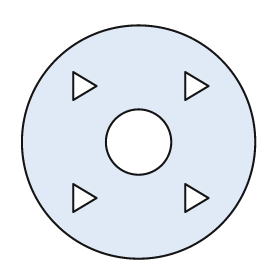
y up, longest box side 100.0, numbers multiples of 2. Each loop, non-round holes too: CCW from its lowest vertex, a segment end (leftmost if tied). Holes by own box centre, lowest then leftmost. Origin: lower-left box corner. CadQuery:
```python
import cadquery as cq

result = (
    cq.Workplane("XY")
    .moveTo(50.0, 50.0)
    .circle(50.0)
    .moveTo(22.0, 20.0)
    .lineTo(32.0, 26.0)
    .lineTo(22.0, 32.0)
    .close()
    .moveTo(70.0, 20.0)
    .lineTo(80.0, 26.0)
    .lineTo(70.0, 32.0)
    .close()
    .moveTo(50.0, 50.0)
    .circle(14.0)
    .moveTo(22.0, 68.0)
    .lineTo(32.0, 74.0)
    .lineTo(22.0, 80.0)
    .close()
    .moveTo(70.0, 68.0)
    .lineTo(80.0, 74.0)
    .lineTo(70.0, 80.0)
    .close()
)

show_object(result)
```